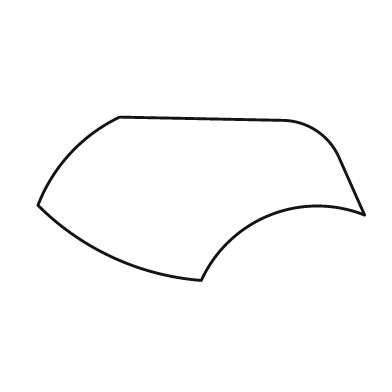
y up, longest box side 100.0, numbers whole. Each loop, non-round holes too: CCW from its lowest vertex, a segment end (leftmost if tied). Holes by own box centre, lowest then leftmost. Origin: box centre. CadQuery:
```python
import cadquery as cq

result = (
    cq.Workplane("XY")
    .moveTo(0.0, -25.0)
    .threePointArc((21.0, -5.0), (50.0, -5.0))
    .lineTo(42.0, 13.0)
    .threePointArc((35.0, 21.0), (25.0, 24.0))
    .lineTo(-25.0, 25.0)
    .threePointArc((-40.0, 14.0), (-50.0, -2.0))
    .threePointArc((-27.0, -18.0), (0.0, -25.0))
    .close()
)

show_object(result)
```